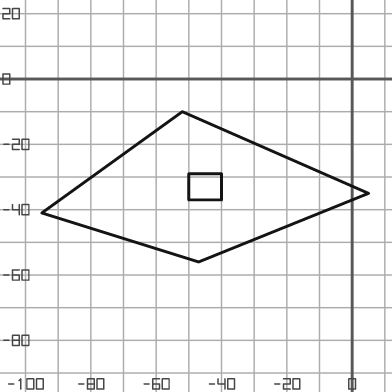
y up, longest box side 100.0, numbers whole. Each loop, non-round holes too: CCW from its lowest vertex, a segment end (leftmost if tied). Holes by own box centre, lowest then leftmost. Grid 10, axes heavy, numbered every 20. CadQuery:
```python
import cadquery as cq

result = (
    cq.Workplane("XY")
    .moveTo(-47.0, -56.0)
    .lineTo(5.0, -35.0)
    .lineTo(-52.0, -10.0)
    .lineTo(-95.0, -41.0)
    .close()
    .moveTo(-50.0, -37.0)
    .lineTo(-40.0, -37.0)
    .lineTo(-40.0, -29.0)
    .lineTo(-50.0, -29.0)
    .close()
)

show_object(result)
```